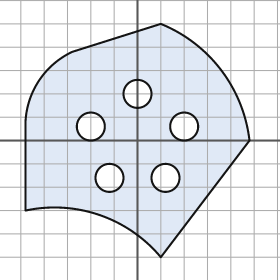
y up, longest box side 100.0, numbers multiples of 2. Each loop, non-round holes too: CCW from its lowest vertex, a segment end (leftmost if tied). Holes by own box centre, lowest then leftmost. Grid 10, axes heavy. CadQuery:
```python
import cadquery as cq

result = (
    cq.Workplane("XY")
    .moveTo(10.0, -50.0)
    .lineTo(48.0, 0.0)
    .threePointArc((36.0, 30.0), (10.0, 50.0))
    .lineTo(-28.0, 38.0)
    .threePointArc((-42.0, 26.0), (-48.0, 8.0))
    .lineTo(-48.0, -30.0)
    .threePointArc((-16.0, -32.0), (10.0, -50.0))
    .close()
    .moveTo(-12.0, -16.0)
    .circle(6.0)
    .moveTo(12.0, -16.0)
    .circle(6.0)
    .moveTo(-20.0, 6.0)
    .circle(6.0)
    .moveTo(20.0, 6.0)
    .circle(6.0)
    .moveTo(0.0, 20.0)
    .circle(6.0)
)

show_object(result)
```